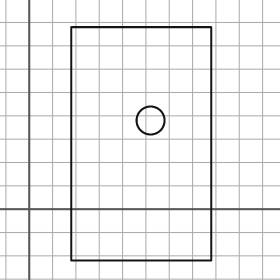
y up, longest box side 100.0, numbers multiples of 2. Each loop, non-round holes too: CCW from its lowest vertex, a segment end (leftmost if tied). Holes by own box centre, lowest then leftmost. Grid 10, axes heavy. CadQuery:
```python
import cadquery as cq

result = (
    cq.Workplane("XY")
    .moveTo(18.0, -22.0)
    .lineTo(78.0, -22.0)
    .lineTo(78.0, 78.0)
    .lineTo(18.0, 78.0)
    .close()
    .moveTo(52.0, 38.0)
    .circle(6.0)
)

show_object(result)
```